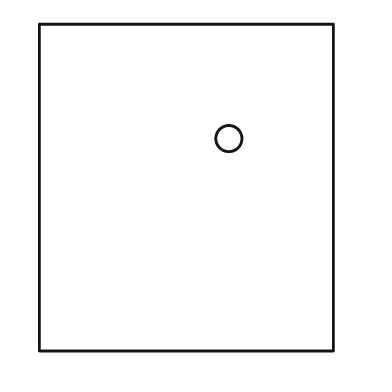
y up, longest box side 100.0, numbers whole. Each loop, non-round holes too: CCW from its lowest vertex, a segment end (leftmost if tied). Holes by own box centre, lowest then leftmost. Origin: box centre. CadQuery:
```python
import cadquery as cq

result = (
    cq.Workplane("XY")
    .moveTo(-45.0, -50.0)
    .lineTo(45.0, -50.0)
    .lineTo(45.0, 50.0)
    .lineTo(-45.0, 50.0)
    .close()
    .moveTo(13.0, 15.0)
    .circle(4.0)
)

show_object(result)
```